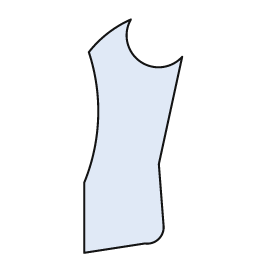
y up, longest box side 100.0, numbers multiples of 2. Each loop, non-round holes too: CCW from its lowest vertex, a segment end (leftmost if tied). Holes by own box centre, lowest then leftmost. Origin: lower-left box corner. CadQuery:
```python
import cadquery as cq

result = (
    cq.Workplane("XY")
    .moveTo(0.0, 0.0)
    .lineTo(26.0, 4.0)
    .threePointArc((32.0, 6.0), (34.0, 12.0))
    .lineTo(32.0, 38.0)
    .lineTo(42.0, 84.0)
    .threePointArc((24.0, 82.0), (20.0, 100.0))
    .threePointArc((10.0, 94.0), (2.0, 86.0))
    .threePointArc((6.0, 58.0), (0.0, 30.0))
    .close()
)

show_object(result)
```